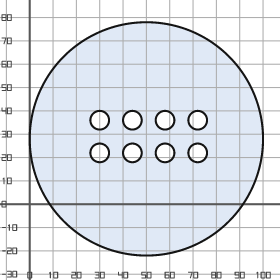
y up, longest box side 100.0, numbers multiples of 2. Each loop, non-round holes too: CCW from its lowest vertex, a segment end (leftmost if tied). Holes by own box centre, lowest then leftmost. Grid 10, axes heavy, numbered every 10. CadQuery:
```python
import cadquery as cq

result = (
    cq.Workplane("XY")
    .moveTo(50.0, 28.0)
    .circle(50.0)
    .moveTo(30.0, 22.0)
    .circle(4.0)
    .moveTo(44.0, 22.0)
    .circle(4.0)
    .moveTo(58.0, 22.0)
    .circle(4.0)
    .moveTo(72.0, 22.0)
    .circle(4.0)
    .moveTo(30.0, 36.0)
    .circle(4.0)
    .moveTo(44.0, 36.0)
    .circle(4.0)
    .moveTo(58.0, 36.0)
    .circle(4.0)
    .moveTo(72.0, 36.0)
    .circle(4.0)
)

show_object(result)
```